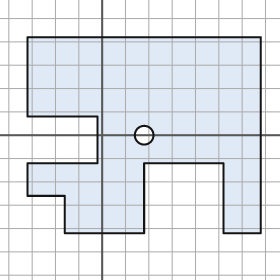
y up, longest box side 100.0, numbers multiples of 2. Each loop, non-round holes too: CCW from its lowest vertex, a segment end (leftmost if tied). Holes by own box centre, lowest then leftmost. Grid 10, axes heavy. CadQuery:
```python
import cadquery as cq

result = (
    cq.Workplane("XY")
    .moveTo(-16.0, -42.0)
    .lineTo(18.0, -42.0)
    .lineTo(18.0, -12.0)
    .lineTo(52.0, -12.0)
    .lineTo(52.0, -42.0)
    .lineTo(68.0, -42.0)
    .lineTo(68.0, 42.0)
    .lineTo(-32.0, 42.0)
    .lineTo(-32.0, 8.0)
    .lineTo(-2.0, 8.0)
    .lineTo(-2.0, -12.0)
    .lineTo(-32.0, -12.0)
    .lineTo(-32.0, -26.0)
    .lineTo(-16.0, -26.0)
    .close()
    .moveTo(18.0, 0.0)
    .circle(4.0)
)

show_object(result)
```